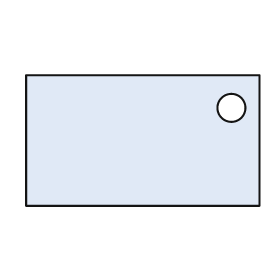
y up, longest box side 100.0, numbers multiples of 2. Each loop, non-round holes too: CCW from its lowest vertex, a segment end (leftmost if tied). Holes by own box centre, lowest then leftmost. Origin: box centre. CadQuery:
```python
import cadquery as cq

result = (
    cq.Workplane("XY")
    .moveTo(-50.0, -28.0)
    .lineTo(50.0, -28.0)
    .lineTo(50.0, 28.0)
    .lineTo(-50.0, 28.0)
    .close()
    .moveTo(38.0, 14.0)
    .circle(6.0)
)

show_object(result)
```